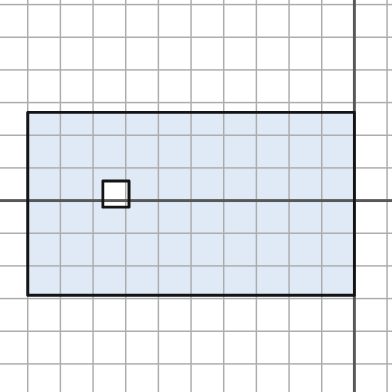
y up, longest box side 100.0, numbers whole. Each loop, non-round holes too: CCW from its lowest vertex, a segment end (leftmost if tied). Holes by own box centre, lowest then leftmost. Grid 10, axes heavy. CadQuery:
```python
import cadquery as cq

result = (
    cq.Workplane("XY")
    .moveTo(-100.0, -29.0)
    .lineTo(0.0, -29.0)
    .lineTo(0.0, 27.0)
    .lineTo(-100.0, 27.0)
    .close()
    .moveTo(-77.0, -2.0)
    .lineTo(-69.0, -2.0)
    .lineTo(-69.0, 6.0)
    .lineTo(-77.0, 6.0)
    .close()
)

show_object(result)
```